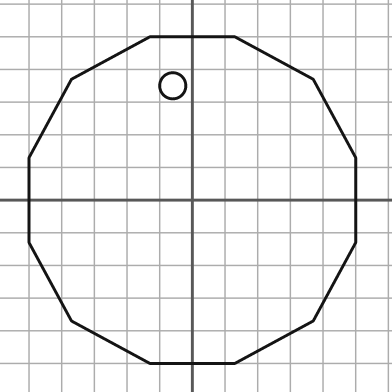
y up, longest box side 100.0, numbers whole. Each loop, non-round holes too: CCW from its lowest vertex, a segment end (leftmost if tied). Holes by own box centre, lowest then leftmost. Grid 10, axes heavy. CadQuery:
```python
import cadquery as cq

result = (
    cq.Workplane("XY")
    .moveTo(-13.0, -50.0)
    .lineTo(13.0, -50.0)
    .lineTo(37.0, -37.0)
    .lineTo(50.0, -13.0)
    .lineTo(50.0, 13.0)
    .lineTo(37.0, 37.0)
    .lineTo(13.0, 50.0)
    .lineTo(-13.0, 50.0)
    .lineTo(-37.0, 37.0)
    .lineTo(-50.0, 13.0)
    .lineTo(-50.0, -13.0)
    .lineTo(-37.0, -37.0)
    .close()
    .moveTo(-6.0, 35.0)
    .circle(4.0)
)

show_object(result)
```